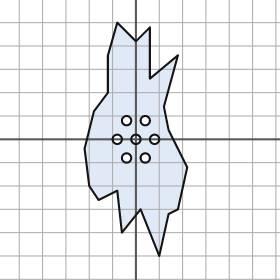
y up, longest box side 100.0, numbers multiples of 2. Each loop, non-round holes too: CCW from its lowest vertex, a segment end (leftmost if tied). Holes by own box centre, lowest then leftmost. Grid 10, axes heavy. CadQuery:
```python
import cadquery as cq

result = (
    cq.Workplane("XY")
    .moveTo(10.0, -50.0)
    .lineTo(14.0, -32.0)
    .lineTo(18.0, -30.0)
    .lineTo(22.0, -12.0)
    .lineTo(14.0, 4.0)
    .lineTo(12.0, 14.0)
    .lineTo(18.0, 36.0)
    .lineTo(6.0, 26.0)
    .lineTo(6.0, 48.0)
    .lineTo(0.0, 42.0)
    .lineTo(-8.0, 50.0)
    .lineTo(-12.0, 36.0)
    .lineTo(-12.0, 20.0)
    .lineTo(-18.0, 12.0)
    .lineTo(-22.0, -4.0)
    .lineTo(-20.0, -20.0)
    .lineTo(-16.0, -26.0)
    .lineTo(-8.0, -22.0)
    .lineTo(-6.0, -40.0)
    .lineTo(2.0, -30.0)
    .close()
    .moveTo(-4.0, -8.0)
    .circle(2.0)
    .moveTo(4.0, -8.0)
    .circle(2.0)
    .moveTo(-8.0, 0.0)
    .circle(2.0)
    .moveTo(0.0, 0.0)
    .circle(2.0)
    .moveTo(8.0, 0.0)
    .circle(2.0)
    .moveTo(-4.0, 8.0)
    .circle(2.0)
    .moveTo(4.0, 8.0)
    .circle(2.0)
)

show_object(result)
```